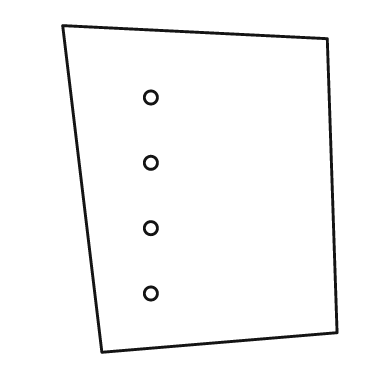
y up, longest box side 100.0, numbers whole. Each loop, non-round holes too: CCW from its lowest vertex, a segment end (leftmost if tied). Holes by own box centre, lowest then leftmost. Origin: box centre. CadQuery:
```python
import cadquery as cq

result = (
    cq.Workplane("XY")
    .moveTo(-30.0, -50.0)
    .lineTo(42.0, -44.0)
    .lineTo(39.0, 46.0)
    .lineTo(-42.0, 50.0)
    .close()
    .moveTo(-15.0, -32.0)
    .circle(2.0)
    .moveTo(-15.0, -12.0)
    .circle(2.0)
    .moveTo(-15.0, 8.0)
    .circle(2.0)
    .moveTo(-15.0, 28.0)
    .circle(2.0)
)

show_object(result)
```